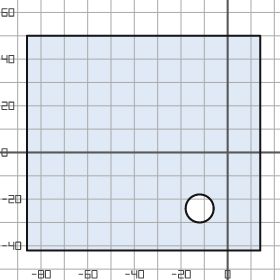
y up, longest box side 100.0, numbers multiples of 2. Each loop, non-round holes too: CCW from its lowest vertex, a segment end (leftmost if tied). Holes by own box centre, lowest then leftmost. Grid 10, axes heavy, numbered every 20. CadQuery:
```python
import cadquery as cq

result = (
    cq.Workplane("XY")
    .moveTo(-86.0, -42.0)
    .lineTo(14.0, -42.0)
    .lineTo(14.0, 50.0)
    .lineTo(-86.0, 50.0)
    .close()
    .moveTo(-12.0, -24.0)
    .circle(6.0)
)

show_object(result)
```